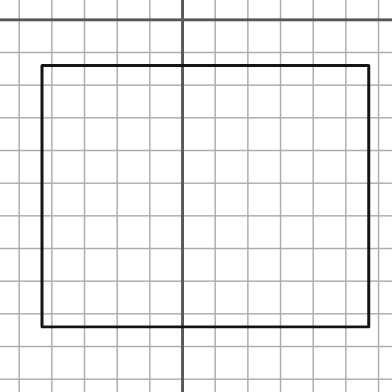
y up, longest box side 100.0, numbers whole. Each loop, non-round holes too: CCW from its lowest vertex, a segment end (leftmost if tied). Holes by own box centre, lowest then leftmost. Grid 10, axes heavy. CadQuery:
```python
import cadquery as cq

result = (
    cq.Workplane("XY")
    .moveTo(-43.0, -94.0)
    .lineTo(57.0, -94.0)
    .lineTo(57.0, -14.0)
    .lineTo(-43.0, -14.0)
    .close()
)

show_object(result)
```